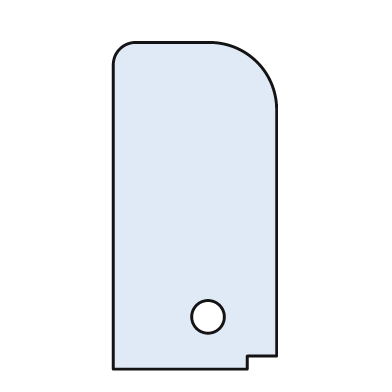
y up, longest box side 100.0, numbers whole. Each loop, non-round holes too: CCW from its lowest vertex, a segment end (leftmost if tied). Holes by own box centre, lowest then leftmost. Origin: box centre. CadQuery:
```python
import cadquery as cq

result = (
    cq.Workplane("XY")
    .moveTo(-25.0, -50.0)
    .lineTo(16.0, -50.0)
    .lineTo(16.0, -46.0)
    .lineTo(25.0, -46.0)
    .lineTo(25.0, 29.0)
    .threePointArc((19.0, 44.0), (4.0, 50.0))
    .lineTo(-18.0, 50.0)
    .threePointArc((-23.0, 48.0), (-25.0, 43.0))
    .close()
    .moveTo(4.0, -34.0)
    .circle(5.0)
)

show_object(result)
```